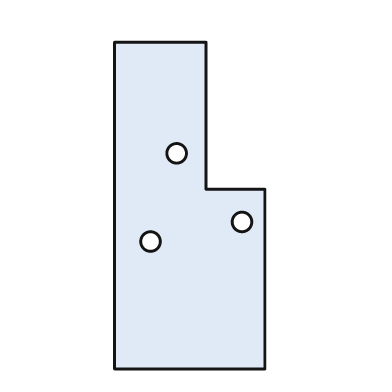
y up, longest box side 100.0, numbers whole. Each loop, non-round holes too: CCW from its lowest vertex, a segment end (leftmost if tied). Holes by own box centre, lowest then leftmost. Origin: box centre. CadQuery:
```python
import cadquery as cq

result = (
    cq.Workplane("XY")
    .moveTo(-23.0, -50.0)
    .lineTo(23.0, -50.0)
    .lineTo(23.0, 5.0)
    .lineTo(5.0, 5.0)
    .lineTo(5.0, 50.0)
    .lineTo(-23.0, 50.0)
    .close()
    .moveTo(-12.0, -11.0)
    .circle(3.0)
    .moveTo(16.0, -5.0)
    .circle(3.0)
    .moveTo(-4.0, 16.0)
    .circle(3.0)
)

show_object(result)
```